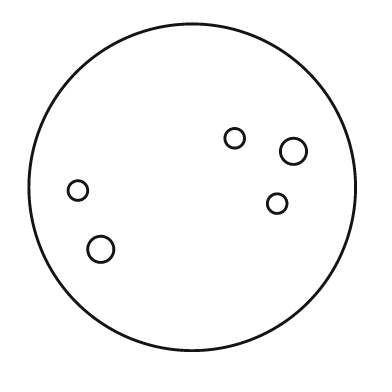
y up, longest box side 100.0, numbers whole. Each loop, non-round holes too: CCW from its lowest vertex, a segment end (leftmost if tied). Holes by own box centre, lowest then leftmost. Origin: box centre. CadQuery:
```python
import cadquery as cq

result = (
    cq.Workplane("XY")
    .moveTo(0.0, 0.0)
    .circle(50.0)
    .moveTo(-28.0, -19.0)
    .circle(4.0)
    .moveTo(26.0, -5.0)
    .circle(3.0)
    .moveTo(-35.0, -1.0)
    .circle(3.0)
    .moveTo(31.0, 11.0)
    .circle(4.0)
    .moveTo(13.0, 15.0)
    .circle(3.0)
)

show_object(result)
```